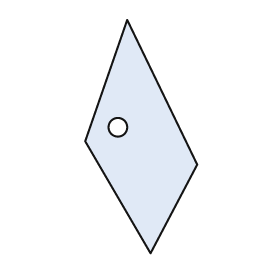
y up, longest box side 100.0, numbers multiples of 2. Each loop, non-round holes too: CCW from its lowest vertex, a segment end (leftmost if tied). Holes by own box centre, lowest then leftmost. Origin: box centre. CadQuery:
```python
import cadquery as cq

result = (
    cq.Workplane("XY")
    .moveTo(4.0, -50.0)
    .lineTo(24.0, -12.0)
    .lineTo(-6.0, 50.0)
    .lineTo(-24.0, -2.0)
    .close()
    .moveTo(-10.0, 4.0)
    .circle(4.0)
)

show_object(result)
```